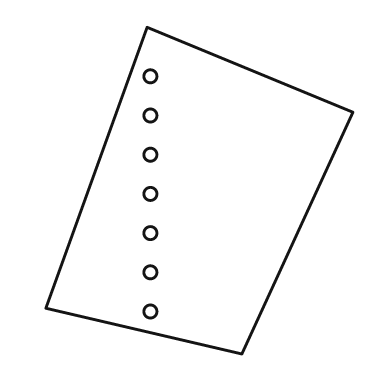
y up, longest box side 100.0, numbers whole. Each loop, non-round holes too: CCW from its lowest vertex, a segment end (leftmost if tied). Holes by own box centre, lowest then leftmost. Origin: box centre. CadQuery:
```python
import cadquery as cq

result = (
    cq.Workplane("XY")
    .moveTo(13.0, -50.0)
    .lineTo(47.0, 24.0)
    .lineTo(-16.0, 50.0)
    .lineTo(-47.0, -36.0)
    .close()
    .moveTo(-15.0, -37.0)
    .circle(2.0)
    .moveTo(-15.0, -25.0)
    .circle(2.0)
    .moveTo(-15.0, -13.0)
    .circle(2.0)
    .moveTo(-15.0, -1.0)
    .circle(2.0)
    .moveTo(-15.0, 11.0)
    .circle(2.0)
    .moveTo(-15.0, 23.0)
    .circle(2.0)
    .moveTo(-15.0, 35.0)
    .circle(2.0)
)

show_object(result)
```